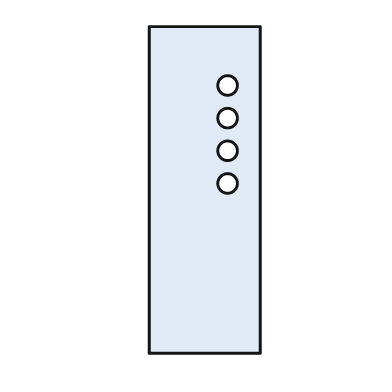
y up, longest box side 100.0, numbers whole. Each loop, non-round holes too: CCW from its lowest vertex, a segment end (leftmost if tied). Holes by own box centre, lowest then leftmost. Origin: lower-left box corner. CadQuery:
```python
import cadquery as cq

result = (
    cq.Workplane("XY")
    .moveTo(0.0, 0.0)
    .lineTo(34.0, 0.0)
    .lineTo(34.0, 100.0)
    .lineTo(0.0, 100.0)
    .close()
    .moveTo(24.0, 52.0)
    .circle(3.0)
    .moveTo(24.0, 62.0)
    .circle(3.0)
    .moveTo(24.0, 72.0)
    .circle(3.0)
    .moveTo(24.0, 82.0)
    .circle(3.0)
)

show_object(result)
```